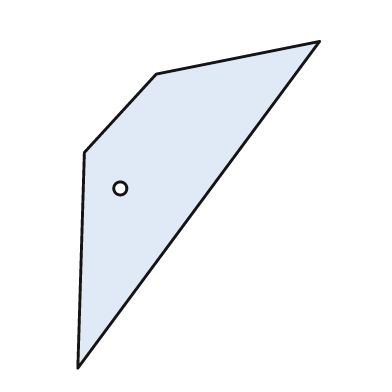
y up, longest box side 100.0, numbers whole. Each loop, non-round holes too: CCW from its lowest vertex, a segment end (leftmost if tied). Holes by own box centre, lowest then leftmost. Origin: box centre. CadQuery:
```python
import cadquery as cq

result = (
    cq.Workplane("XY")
    .moveTo(-37.0, -50.0)
    .lineTo(37.0, 50.0)
    .lineTo(-13.0, 40.0)
    .lineTo(-35.0, 16.0)
    .close()
    .moveTo(-24.0, 5.0)
    .circle(2.0)
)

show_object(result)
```